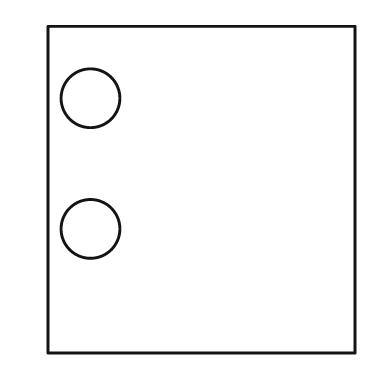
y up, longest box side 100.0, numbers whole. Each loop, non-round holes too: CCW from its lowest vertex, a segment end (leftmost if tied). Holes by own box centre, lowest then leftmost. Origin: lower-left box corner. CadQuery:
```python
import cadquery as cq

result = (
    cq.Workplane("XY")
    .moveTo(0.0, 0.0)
    .lineTo(94.0, 0.0)
    .lineTo(94.0, 100.0)
    .lineTo(0.0, 100.0)
    .close()
    .moveTo(13.0, 38.0)
    .circle(9.0)
    .moveTo(13.0, 78.0)
    .circle(9.0)
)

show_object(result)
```